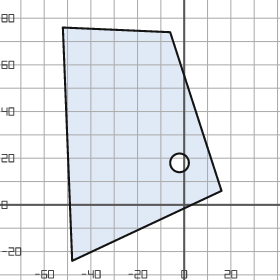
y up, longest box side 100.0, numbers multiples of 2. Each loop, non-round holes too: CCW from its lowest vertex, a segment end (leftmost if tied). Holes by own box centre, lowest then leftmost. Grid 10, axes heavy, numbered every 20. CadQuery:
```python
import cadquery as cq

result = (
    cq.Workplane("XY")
    .moveTo(-48.0, -24.0)
    .lineTo(16.0, 6.0)
    .lineTo(-6.0, 74.0)
    .lineTo(-52.0, 76.0)
    .close()
    .moveTo(-2.0, 18.0)
    .circle(4.0)
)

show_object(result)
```